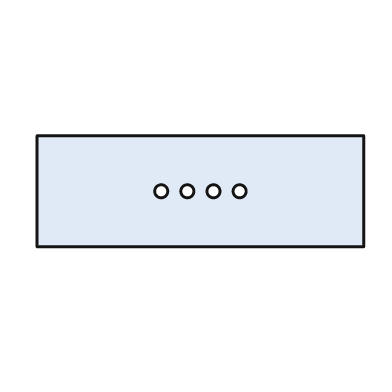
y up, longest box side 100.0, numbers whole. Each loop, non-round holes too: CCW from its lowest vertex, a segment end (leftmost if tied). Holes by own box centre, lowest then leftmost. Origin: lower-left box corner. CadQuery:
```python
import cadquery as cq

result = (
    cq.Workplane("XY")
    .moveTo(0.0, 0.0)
    .lineTo(100.0, 0.0)
    .lineTo(100.0, 34.0)
    .lineTo(0.0, 34.0)
    .close()
    .moveTo(38.0, 17.0)
    .circle(2.0)
    .moveTo(46.0, 17.0)
    .circle(2.0)
    .moveTo(54.0, 17.0)
    .circle(2.0)
    .moveTo(62.0, 17.0)
    .circle(2.0)
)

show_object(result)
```